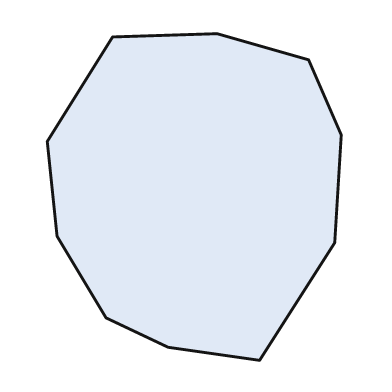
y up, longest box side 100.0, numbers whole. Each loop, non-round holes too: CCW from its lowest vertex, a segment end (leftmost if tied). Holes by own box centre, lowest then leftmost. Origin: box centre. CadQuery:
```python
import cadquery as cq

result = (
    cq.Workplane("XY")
    .moveTo(20.0, -50.0)
    .lineTo(43.0, -14.0)
    .lineTo(45.0, 19.0)
    .lineTo(35.0, 42.0)
    .lineTo(7.0, 50.0)
    .lineTo(-25.0, 49.0)
    .lineTo(-45.0, 17.0)
    .lineTo(-42.0, -12.0)
    .lineTo(-27.0, -37.0)
    .lineTo(-8.0, -46.0)
    .close()
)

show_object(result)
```